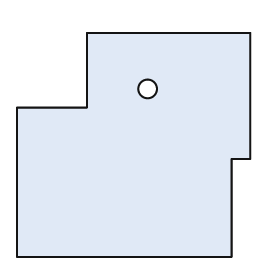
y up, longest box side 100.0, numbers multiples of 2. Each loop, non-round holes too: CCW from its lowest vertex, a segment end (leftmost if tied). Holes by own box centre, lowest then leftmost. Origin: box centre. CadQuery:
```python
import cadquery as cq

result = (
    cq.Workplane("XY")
    .moveTo(-50.0, -48.0)
    .lineTo(42.0, -48.0)
    .lineTo(42.0, -6.0)
    .lineTo(50.0, -6.0)
    .lineTo(50.0, 48.0)
    .lineTo(-20.0, 48.0)
    .lineTo(-20.0, 16.0)
    .lineTo(-50.0, 16.0)
    .close()
    .moveTo(6.0, 24.0)
    .circle(4.0)
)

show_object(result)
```